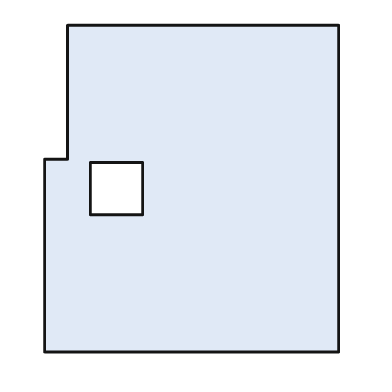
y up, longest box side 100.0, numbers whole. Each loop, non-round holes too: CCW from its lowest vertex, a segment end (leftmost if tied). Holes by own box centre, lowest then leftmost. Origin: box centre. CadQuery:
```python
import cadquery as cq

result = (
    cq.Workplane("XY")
    .moveTo(-45.0, -50.0)
    .lineTo(45.0, -50.0)
    .lineTo(45.0, 50.0)
    .lineTo(-38.0, 50.0)
    .lineTo(-38.0, 9.0)
    .lineTo(-45.0, 9.0)
    .close()
    .moveTo(-31.0, -8.0)
    .lineTo(-15.0, -8.0)
    .lineTo(-15.0, 8.0)
    .lineTo(-31.0, 8.0)
    .close()
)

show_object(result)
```